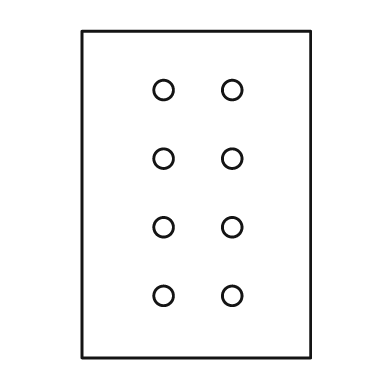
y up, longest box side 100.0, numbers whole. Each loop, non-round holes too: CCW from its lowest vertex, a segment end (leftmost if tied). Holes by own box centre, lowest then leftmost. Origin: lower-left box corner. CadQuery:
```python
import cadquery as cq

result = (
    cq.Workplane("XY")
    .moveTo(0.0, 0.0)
    .lineTo(70.0, 0.0)
    .lineTo(70.0, 100.0)
    .lineTo(0.0, 100.0)
    .close()
    .moveTo(25.0, 19.0)
    .circle(3.0)
    .moveTo(46.0, 19.0)
    .circle(3.0)
    .moveTo(25.0, 40.0)
    .circle(3.0)
    .moveTo(46.0, 40.0)
    .circle(3.0)
    .moveTo(25.0, 61.0)
    .circle(3.0)
    .moveTo(46.0, 61.0)
    .circle(3.0)
    .moveTo(25.0, 82.0)
    .circle(3.0)
    .moveTo(46.0, 82.0)
    .circle(3.0)
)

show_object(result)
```